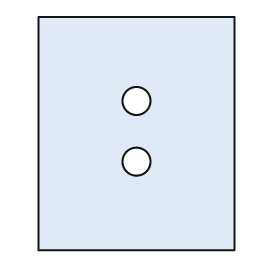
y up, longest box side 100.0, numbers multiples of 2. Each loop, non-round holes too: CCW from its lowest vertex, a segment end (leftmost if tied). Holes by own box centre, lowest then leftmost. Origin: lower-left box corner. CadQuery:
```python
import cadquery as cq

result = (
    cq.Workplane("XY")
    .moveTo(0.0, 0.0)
    .lineTo(84.0, 0.0)
    .lineTo(84.0, 100.0)
    .lineTo(0.0, 100.0)
    .close()
    .moveTo(42.0, 38.0)
    .circle(6.0)
    .moveTo(42.0, 64.0)
    .circle(6.0)
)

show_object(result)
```